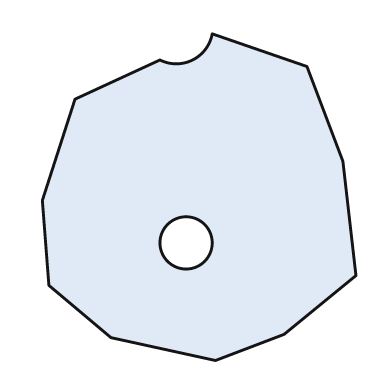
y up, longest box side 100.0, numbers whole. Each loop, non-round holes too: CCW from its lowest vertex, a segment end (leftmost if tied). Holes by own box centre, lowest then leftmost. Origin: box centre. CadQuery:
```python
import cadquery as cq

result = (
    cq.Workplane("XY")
    .moveTo(5.0, -50.0)
    .lineTo(26.0, -42.0)
    .lineTo(48.0, -24.0)
    .lineTo(44.0, 11.0)
    .lineTo(33.0, 40.0)
    .lineTo(4.0, 50.0)
    .threePointArc((-2.0, 42.0), (-12.0, 42.0))
    .lineTo(-38.0, 30.0)
    .lineTo(-48.0, -1.0)
    .lineTo(-46.0, -27.0)
    .lineTo(-27.0, -43.0)
    .close()
    .moveTo(-4.0, -14.0)
    .circle(8.0)
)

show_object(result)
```